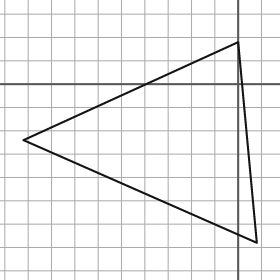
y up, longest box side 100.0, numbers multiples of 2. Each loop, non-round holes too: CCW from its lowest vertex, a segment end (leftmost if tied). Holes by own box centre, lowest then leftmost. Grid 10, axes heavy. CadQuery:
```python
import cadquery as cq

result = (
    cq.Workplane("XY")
    .moveTo(8.0, -68.0)
    .lineTo(0.0, 18.0)
    .lineTo(-92.0, -24.0)
    .close()
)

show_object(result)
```